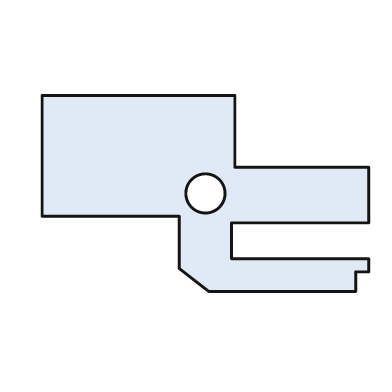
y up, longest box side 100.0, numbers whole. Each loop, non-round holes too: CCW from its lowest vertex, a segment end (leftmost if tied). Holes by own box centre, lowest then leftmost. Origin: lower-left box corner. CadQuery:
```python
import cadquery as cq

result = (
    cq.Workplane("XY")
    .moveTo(51.0, 0.0)
    .lineTo(96.0, 0.0)
    .lineTo(96.0, 6.0)
    .lineTo(100.0, 6.0)
    .lineTo(100.0, 10.0)
    .lineTo(58.0, 10.0)
    .lineTo(58.0, 21.0)
    .lineTo(100.0, 21.0)
    .lineTo(100.0, 38.0)
    .lineTo(59.0, 38.0)
    .lineTo(59.0, 60.0)
    .lineTo(0.0, 60.0)
    .lineTo(0.0, 23.0)
    .lineTo(42.0, 23.0)
    .lineTo(42.0, 7.0)
    .close()
    .moveTo(50.0, 30.0)
    .circle(6.0)
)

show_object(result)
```